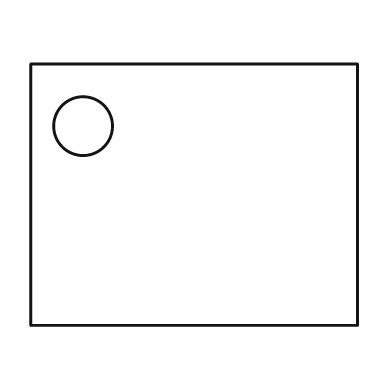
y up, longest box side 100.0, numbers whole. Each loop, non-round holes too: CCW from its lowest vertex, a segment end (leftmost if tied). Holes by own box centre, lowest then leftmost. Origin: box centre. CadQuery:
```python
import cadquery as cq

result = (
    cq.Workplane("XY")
    .moveTo(-50.0, -40.0)
    .lineTo(50.0, -40.0)
    .lineTo(50.0, 40.0)
    .lineTo(-50.0, 40.0)
    .close()
    .moveTo(-34.0, 21.0)
    .circle(9.0)
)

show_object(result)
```